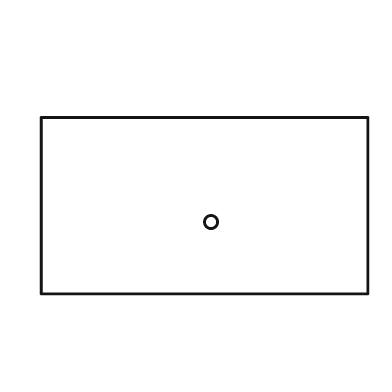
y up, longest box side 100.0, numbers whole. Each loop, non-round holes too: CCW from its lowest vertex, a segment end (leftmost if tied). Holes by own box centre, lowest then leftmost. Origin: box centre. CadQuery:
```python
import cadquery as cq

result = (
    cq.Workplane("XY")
    .moveTo(-50.0, -27.0)
    .lineTo(50.0, -27.0)
    .lineTo(50.0, 27.0)
    .lineTo(-50.0, 27.0)
    .close()
    .moveTo(2.0, -5.0)
    .circle(2.0)
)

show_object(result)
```